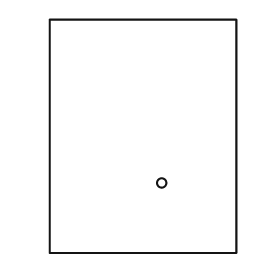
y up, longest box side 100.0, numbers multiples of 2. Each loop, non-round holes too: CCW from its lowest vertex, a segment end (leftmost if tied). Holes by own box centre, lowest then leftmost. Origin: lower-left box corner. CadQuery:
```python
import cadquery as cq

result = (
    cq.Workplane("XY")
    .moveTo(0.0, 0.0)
    .lineTo(80.0, 0.0)
    .lineTo(80.0, 100.0)
    .lineTo(0.0, 100.0)
    .close()
    .moveTo(48.0, 30.0)
    .circle(2.0)
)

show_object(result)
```